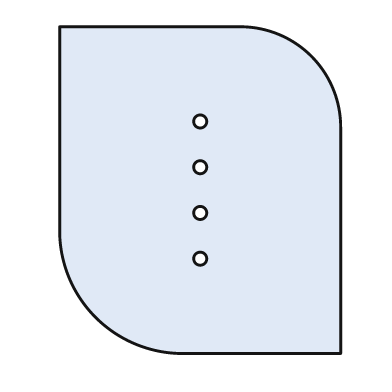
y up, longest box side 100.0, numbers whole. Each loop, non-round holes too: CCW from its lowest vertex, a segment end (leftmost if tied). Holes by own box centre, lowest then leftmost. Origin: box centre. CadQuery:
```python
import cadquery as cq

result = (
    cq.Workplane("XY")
    .moveTo(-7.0, -50.0)
    .lineTo(43.0, -50.0)
    .lineTo(43.0, 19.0)
    .threePointArc((34.0, 41.0), (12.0, 50.0))
    .lineTo(-43.0, 50.0)
    .lineTo(-43.0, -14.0)
    .threePointArc((-32.0, -39.0), (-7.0, -50.0))
    .close()
    .moveTo(0.0, -21.0)
    .circle(2.0)
    .moveTo(0.0, -7.0)
    .circle(2.0)
    .moveTo(0.0, 7.0)
    .circle(2.0)
    .moveTo(0.0, 21.0)
    .circle(2.0)
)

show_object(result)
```